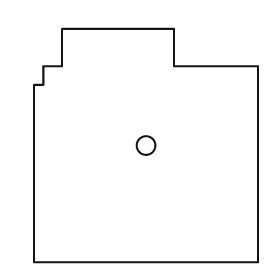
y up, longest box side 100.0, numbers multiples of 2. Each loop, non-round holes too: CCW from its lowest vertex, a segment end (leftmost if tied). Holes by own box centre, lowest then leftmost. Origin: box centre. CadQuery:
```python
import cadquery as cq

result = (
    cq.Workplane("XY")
    .moveTo(-48.0, -50.0)
    .lineTo(48.0, -50.0)
    .lineTo(48.0, 34.0)
    .lineTo(12.0, 34.0)
    .lineTo(12.0, 50.0)
    .lineTo(-36.0, 50.0)
    .lineTo(-36.0, 34.0)
    .lineTo(-44.0, 34.0)
    .lineTo(-44.0, 26.0)
    .lineTo(-48.0, 26.0)
    .close()
    .moveTo(0.0, 0.0)
    .circle(4.0)
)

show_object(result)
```